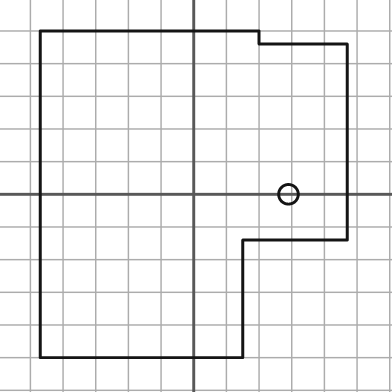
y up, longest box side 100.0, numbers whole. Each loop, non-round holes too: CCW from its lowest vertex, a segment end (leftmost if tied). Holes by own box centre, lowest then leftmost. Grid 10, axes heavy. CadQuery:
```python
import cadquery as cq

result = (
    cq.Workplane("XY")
    .moveTo(-47.0, -50.0)
    .lineTo(15.0, -50.0)
    .lineTo(15.0, -14.0)
    .lineTo(47.0, -14.0)
    .lineTo(47.0, 46.0)
    .lineTo(20.0, 46.0)
    .lineTo(20.0, 50.0)
    .lineTo(-47.0, 50.0)
    .close()
    .moveTo(29.0, 0.0)
    .circle(3.0)
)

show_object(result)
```